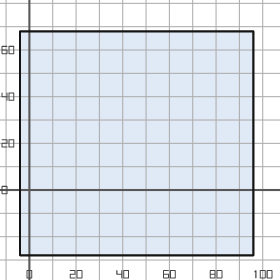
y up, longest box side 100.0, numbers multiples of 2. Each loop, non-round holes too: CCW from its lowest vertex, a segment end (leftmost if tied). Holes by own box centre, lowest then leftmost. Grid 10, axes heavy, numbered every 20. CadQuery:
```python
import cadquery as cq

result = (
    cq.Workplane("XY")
    .moveTo(-4.0, -28.0)
    .lineTo(96.0, -28.0)
    .lineTo(96.0, 68.0)
    .lineTo(-4.0, 68.0)
    .close()
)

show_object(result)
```